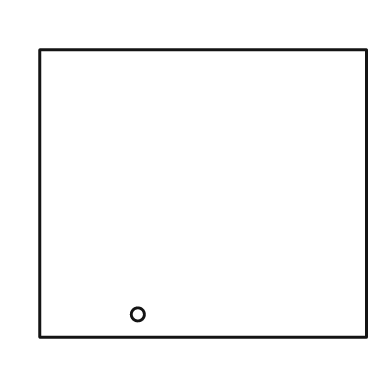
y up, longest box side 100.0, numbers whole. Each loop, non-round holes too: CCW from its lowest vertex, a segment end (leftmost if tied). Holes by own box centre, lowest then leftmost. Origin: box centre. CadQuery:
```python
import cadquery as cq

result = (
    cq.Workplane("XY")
    .moveTo(-50.0, -44.0)
    .lineTo(50.0, -44.0)
    .lineTo(50.0, 44.0)
    .lineTo(-50.0, 44.0)
    .close()
    .moveTo(-20.0, -37.0)
    .circle(2.0)
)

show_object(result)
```